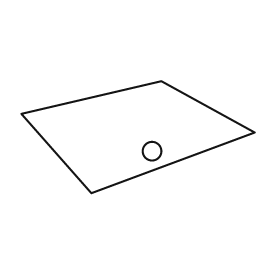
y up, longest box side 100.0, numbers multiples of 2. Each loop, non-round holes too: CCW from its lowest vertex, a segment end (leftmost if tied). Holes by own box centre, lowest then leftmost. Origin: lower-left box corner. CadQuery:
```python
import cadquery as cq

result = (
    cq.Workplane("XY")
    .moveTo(30.0, 0.0)
    .lineTo(100.0, 26.0)
    .lineTo(60.0, 48.0)
    .lineTo(0.0, 34.0)
    .close()
    .moveTo(56.0, 18.0)
    .circle(4.0)
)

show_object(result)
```